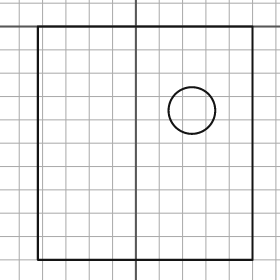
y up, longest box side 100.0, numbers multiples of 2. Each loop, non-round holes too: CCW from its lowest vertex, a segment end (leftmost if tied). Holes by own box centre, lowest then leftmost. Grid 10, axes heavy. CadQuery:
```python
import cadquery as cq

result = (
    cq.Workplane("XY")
    .moveTo(-42.0, -100.0)
    .lineTo(50.0, -100.0)
    .lineTo(50.0, 0.0)
    .lineTo(-42.0, 0.0)
    .close()
    .moveTo(24.0, -36.0)
    .circle(10.0)
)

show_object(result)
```